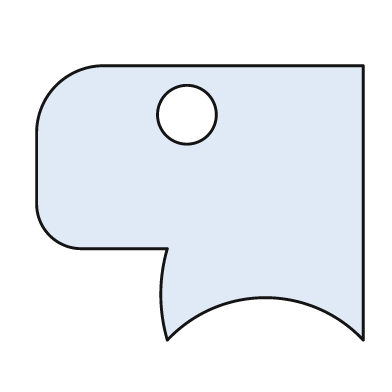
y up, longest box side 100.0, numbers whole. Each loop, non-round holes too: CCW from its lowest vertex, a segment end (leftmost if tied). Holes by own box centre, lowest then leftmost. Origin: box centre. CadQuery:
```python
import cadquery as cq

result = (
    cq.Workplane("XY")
    .moveTo(-10.0, -42.0)
    .threePointArc((20.0, -29.0), (50.0, -42.0))
    .lineTo(50.0, 42.0)
    .lineTo(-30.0, 42.0)
    .threePointArc((-44.0, 36.0), (-50.0, 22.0))
    .lineTo(-50.0, 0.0)
    .threePointArc((-46.0, -10.0), (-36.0, -14.0))
    .lineTo(-10.0, -14.0)
    .threePointArc((-12.0, -28.0), (-10.0, -42.0))
    .close()
    .moveTo(-4.0, 27.0)
    .circle(9.0)
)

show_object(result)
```